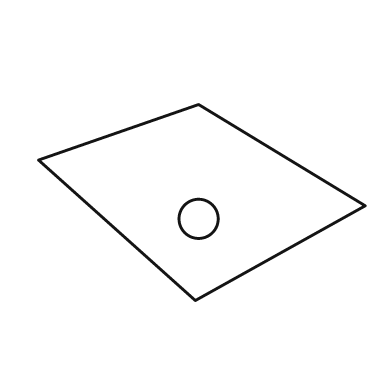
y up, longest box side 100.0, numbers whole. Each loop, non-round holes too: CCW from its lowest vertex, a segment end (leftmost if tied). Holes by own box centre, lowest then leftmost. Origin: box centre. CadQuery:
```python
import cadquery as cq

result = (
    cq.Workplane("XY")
    .moveTo(-2.0, -30.0)
    .lineTo(50.0, -1.0)
    .lineTo(-1.0, 30.0)
    .lineTo(-50.0, 13.0)
    .close()
    .moveTo(-1.0, -5.0)
    .circle(6.0)
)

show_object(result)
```